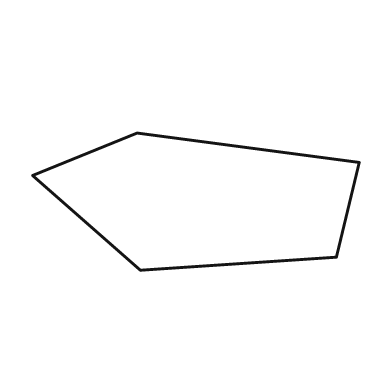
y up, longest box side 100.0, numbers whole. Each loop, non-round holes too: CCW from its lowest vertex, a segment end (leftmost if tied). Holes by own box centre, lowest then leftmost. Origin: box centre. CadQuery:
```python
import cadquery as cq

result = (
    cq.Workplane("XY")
    .moveTo(-17.0, -21.0)
    .lineTo(43.0, -17.0)
    .lineTo(50.0, 12.0)
    .lineTo(-18.0, 21.0)
    .lineTo(-50.0, 8.0)
    .close()
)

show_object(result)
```